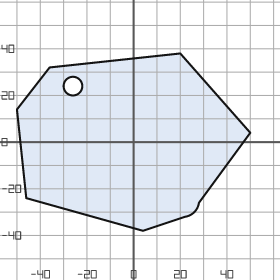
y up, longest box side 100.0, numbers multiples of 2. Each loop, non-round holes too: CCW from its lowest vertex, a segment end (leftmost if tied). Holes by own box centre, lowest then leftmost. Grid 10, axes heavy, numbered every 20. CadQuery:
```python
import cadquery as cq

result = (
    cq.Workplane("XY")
    .moveTo(4.0, -38.0)
    .lineTo(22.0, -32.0)
    .threePointArc((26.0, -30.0), (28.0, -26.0))
    .lineTo(50.0, 4.0)
    .lineTo(20.0, 38.0)
    .lineTo(-36.0, 32.0)
    .lineTo(-50.0, 14.0)
    .lineTo(-46.0, -24.0)
    .close()
    .moveTo(-26.0, 24.0)
    .circle(4.0)
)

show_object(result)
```